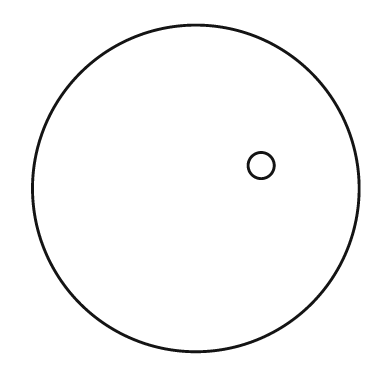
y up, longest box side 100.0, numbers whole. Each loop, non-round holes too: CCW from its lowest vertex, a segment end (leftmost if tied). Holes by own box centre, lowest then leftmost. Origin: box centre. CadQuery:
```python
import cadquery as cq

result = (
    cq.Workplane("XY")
    .moveTo(0.0, 0.0)
    .circle(50.0)
    .moveTo(20.0, 7.0)
    .circle(4.0)
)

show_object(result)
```